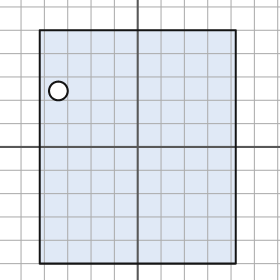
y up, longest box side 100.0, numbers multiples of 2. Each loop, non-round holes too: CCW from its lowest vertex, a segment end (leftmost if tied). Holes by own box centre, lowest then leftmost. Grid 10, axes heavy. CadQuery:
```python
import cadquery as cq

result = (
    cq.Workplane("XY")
    .moveTo(-42.0, -50.0)
    .lineTo(42.0, -50.0)
    .lineTo(42.0, 50.0)
    .lineTo(-42.0, 50.0)
    .close()
    .moveTo(-34.0, 24.0)
    .circle(4.0)
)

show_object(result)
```